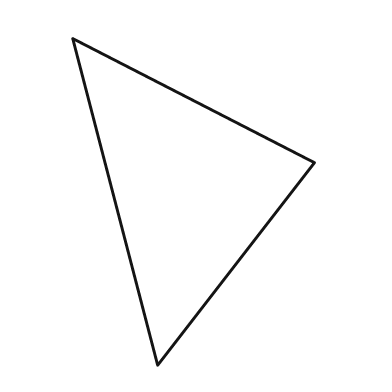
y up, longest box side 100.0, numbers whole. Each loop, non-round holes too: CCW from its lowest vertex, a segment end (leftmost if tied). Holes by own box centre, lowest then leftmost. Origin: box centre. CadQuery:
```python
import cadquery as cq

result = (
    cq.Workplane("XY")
    .moveTo(-11.0, -50.0)
    .lineTo(37.0, 12.0)
    .lineTo(-37.0, 50.0)
    .close()
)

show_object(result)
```